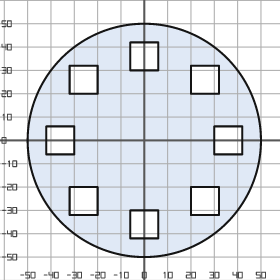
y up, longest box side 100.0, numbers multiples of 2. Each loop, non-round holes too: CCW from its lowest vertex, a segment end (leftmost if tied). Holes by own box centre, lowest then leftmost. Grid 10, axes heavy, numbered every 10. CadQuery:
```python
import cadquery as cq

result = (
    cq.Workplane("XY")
    .moveTo(0.0, 0.0)
    .circle(50.0)
    .moveTo(-6.0, -42.0)
    .lineTo(6.0, -42.0)
    .lineTo(6.0, -30.0)
    .lineTo(-6.0, -30.0)
    .close()
    .moveTo(-32.0, -32.0)
    .lineTo(-20.0, -32.0)
    .lineTo(-20.0, -20.0)
    .lineTo(-32.0, -20.0)
    .close()
    .moveTo(20.0, -32.0)
    .lineTo(32.0, -32.0)
    .lineTo(32.0, -20.0)
    .lineTo(20.0, -20.0)
    .close()
    .moveTo(-42.0, -6.0)
    .lineTo(-30.0, -6.0)
    .lineTo(-30.0, 6.0)
    .lineTo(-42.0, 6.0)
    .close()
    .moveTo(30.0, -6.0)
    .lineTo(42.0, -6.0)
    .lineTo(42.0, 6.0)
    .lineTo(30.0, 6.0)
    .close()
    .moveTo(-32.0, 20.0)
    .lineTo(-20.0, 20.0)
    .lineTo(-20.0, 32.0)
    .lineTo(-32.0, 32.0)
    .close()
    .moveTo(20.0, 20.0)
    .lineTo(32.0, 20.0)
    .lineTo(32.0, 32.0)
    .lineTo(20.0, 32.0)
    .close()
    .moveTo(-6.0, 30.0)
    .lineTo(6.0, 30.0)
    .lineTo(6.0, 42.0)
    .lineTo(-6.0, 42.0)
    .close()
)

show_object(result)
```